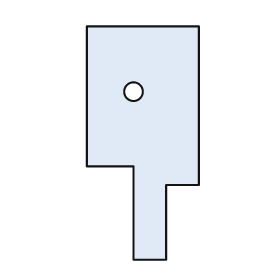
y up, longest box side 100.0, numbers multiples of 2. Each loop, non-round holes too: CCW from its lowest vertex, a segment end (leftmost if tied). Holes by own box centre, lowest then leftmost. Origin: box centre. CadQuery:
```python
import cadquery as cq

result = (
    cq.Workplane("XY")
    .moveTo(-4.0, -50.0)
    .lineTo(10.0, -50.0)
    .lineTo(10.0, -18.0)
    .lineTo(24.0, -18.0)
    .lineTo(24.0, 50.0)
    .lineTo(-24.0, 50.0)
    .lineTo(-24.0, -10.0)
    .lineTo(-4.0, -10.0)
    .close()
    .moveTo(-4.0, 22.0)
    .circle(4.0)
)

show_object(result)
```